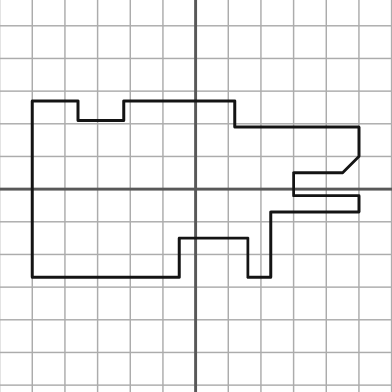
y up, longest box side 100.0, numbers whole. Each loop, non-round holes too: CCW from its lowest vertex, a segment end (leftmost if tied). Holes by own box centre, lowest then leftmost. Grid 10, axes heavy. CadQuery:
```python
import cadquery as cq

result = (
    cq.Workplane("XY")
    .moveTo(-50.0, -27.0)
    .lineTo(-5.0, -27.0)
    .lineTo(-5.0, -15.0)
    .lineTo(16.0, -15.0)
    .lineTo(16.0, -27.0)
    .lineTo(23.0, -27.0)
    .lineTo(23.0, -7.0)
    .lineTo(50.0, -7.0)
    .lineTo(50.0, -2.0)
    .lineTo(30.0, -2.0)
    .lineTo(30.0, 5.0)
    .lineTo(45.0, 5.0)
    .lineTo(50.0, 10.0)
    .lineTo(50.0, 19.0)
    .lineTo(12.0, 19.0)
    .lineTo(12.0, 27.0)
    .lineTo(-22.0, 27.0)
    .lineTo(-22.0, 21.0)
    .lineTo(-36.0, 21.0)
    .lineTo(-36.0, 27.0)
    .lineTo(-50.0, 27.0)
    .close()
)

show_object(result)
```